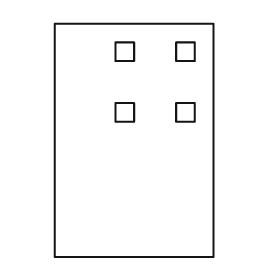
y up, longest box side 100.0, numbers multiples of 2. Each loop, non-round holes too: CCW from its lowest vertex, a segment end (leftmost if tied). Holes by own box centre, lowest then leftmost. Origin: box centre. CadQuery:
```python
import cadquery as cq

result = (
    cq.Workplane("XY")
    .moveTo(-34.0, -50.0)
    .lineTo(34.0, -50.0)
    .lineTo(34.0, 50.0)
    .lineTo(-34.0, 50.0)
    .close()
    .moveTo(-8.0, 8.0)
    .lineTo(0.0, 8.0)
    .lineTo(0.0, 16.0)
    .lineTo(-8.0, 16.0)
    .close()
    .moveTo(18.0, 8.0)
    .lineTo(26.0, 8.0)
    .lineTo(26.0, 16.0)
    .lineTo(18.0, 16.0)
    .close()
    .moveTo(-8.0, 34.0)
    .lineTo(0.0, 34.0)
    .lineTo(0.0, 42.0)
    .lineTo(-8.0, 42.0)
    .close()
    .moveTo(18.0, 34.0)
    .lineTo(26.0, 34.0)
    .lineTo(26.0, 42.0)
    .lineTo(18.0, 42.0)
    .close()
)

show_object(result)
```